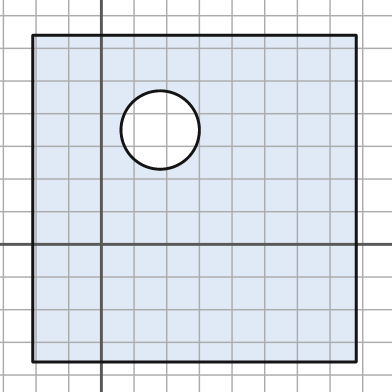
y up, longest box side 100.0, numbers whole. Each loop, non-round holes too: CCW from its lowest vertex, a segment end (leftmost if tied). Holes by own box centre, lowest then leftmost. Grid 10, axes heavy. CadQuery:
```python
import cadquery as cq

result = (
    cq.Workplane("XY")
    .moveTo(-21.0, -36.0)
    .lineTo(78.0, -36.0)
    .lineTo(78.0, 64.0)
    .lineTo(-21.0, 64.0)
    .close()
    .moveTo(18.0, 35.0)
    .circle(12.0)
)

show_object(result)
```